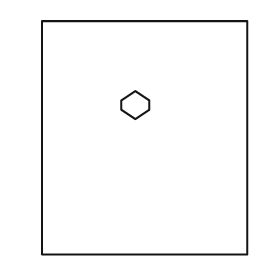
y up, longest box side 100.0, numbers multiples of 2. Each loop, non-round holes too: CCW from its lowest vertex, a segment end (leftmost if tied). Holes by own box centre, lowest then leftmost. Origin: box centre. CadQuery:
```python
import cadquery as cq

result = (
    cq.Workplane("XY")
    .moveTo(-44.0, -50.0)
    .lineTo(44.0, -50.0)
    .lineTo(44.0, 50.0)
    .lineTo(-44.0, 50.0)
    .close()
    .moveTo(-4.0, 8.0)
    .lineTo(2.0, 12.0)
    .lineTo(2.0, 16.0)
    .lineTo(-4.0, 20.0)
    .lineTo(-10.0, 16.0)
    .lineTo(-10.0, 12.0)
    .close()
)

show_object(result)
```